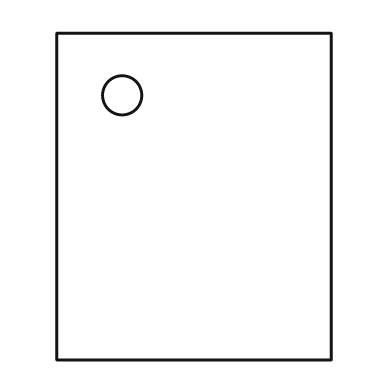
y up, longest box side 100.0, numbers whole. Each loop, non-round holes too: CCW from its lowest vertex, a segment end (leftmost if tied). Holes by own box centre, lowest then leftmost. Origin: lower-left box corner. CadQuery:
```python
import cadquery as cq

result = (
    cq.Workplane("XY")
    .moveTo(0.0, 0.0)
    .lineTo(84.0, 0.0)
    .lineTo(84.0, 100.0)
    .lineTo(0.0, 100.0)
    .close()
    .moveTo(20.0, 81.0)
    .circle(6.0)
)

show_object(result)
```